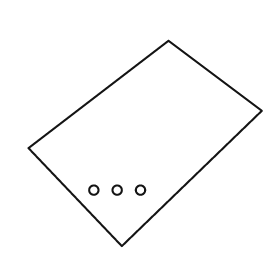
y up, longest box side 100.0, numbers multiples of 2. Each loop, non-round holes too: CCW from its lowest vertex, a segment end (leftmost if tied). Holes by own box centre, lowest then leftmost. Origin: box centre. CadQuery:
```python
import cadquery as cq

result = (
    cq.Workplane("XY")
    .moveTo(-10.0, -44.0)
    .lineTo(50.0, 14.0)
    .lineTo(10.0, 44.0)
    .lineTo(-50.0, -2.0)
    .close()
    .moveTo(-22.0, -20.0)
    .circle(2.0)
    .moveTo(-12.0, -20.0)
    .circle(2.0)
    .moveTo(-2.0, -20.0)
    .circle(2.0)
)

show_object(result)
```